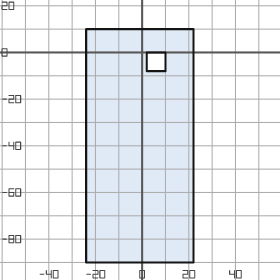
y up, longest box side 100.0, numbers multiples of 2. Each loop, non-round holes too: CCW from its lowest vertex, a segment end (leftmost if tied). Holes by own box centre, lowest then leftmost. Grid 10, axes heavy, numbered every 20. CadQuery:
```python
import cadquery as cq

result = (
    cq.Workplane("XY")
    .moveTo(-24.0, -90.0)
    .lineTo(22.0, -90.0)
    .lineTo(22.0, 10.0)
    .lineTo(-24.0, 10.0)
    .close()
    .moveTo(2.0, -8.0)
    .lineTo(10.0, -8.0)
    .lineTo(10.0, 0.0)
    .lineTo(2.0, 0.0)
    .close()
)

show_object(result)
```